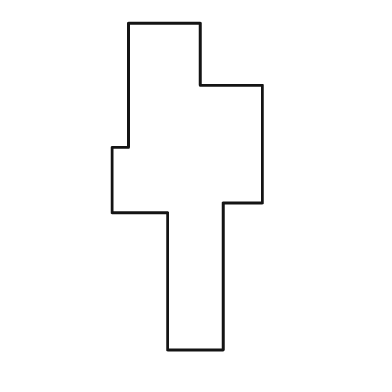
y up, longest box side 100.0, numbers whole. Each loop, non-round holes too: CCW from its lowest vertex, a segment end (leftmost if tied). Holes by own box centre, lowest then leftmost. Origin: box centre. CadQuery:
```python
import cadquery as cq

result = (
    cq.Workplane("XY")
    .moveTo(-6.0, -50.0)
    .lineTo(11.0, -50.0)
    .lineTo(11.0, -5.0)
    .lineTo(23.0, -5.0)
    .lineTo(23.0, 31.0)
    .lineTo(4.0, 31.0)
    .lineTo(4.0, 50.0)
    .lineTo(-18.0, 50.0)
    .lineTo(-18.0, 12.0)
    .lineTo(-23.0, 12.0)
    .lineTo(-23.0, -8.0)
    .lineTo(-6.0, -8.0)
    .close()
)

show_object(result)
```